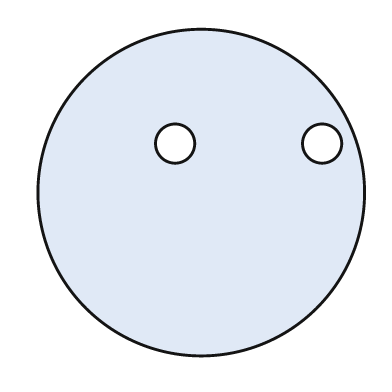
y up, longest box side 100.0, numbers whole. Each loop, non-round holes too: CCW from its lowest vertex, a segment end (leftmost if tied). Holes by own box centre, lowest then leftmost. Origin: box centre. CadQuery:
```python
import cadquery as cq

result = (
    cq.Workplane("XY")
    .moveTo(0.0, 0.0)
    .circle(50.0)
    .moveTo(-8.0, 15.0)
    .circle(6.0)
    .moveTo(37.0, 15.0)
    .circle(6.0)
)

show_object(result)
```